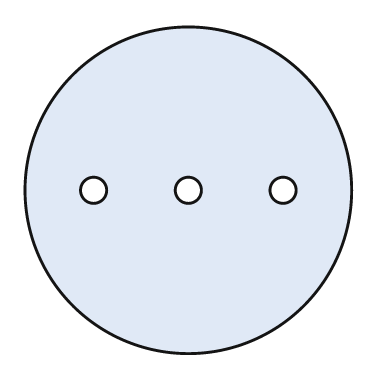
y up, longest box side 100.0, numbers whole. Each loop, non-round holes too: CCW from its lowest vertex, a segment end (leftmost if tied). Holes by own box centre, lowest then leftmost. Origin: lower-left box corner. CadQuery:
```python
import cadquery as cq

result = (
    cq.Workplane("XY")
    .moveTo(50.0, 50.0)
    .circle(50.0)
    .moveTo(21.0, 50.0)
    .circle(4.0)
    .moveTo(50.0, 50.0)
    .circle(4.0)
    .moveTo(79.0, 50.0)
    .circle(4.0)
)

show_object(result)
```